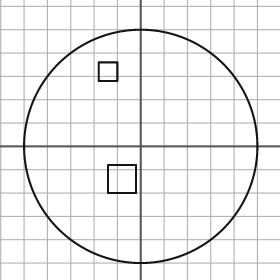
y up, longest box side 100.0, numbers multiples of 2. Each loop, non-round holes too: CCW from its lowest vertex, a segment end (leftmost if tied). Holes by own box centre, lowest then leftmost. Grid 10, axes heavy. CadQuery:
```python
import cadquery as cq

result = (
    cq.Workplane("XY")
    .moveTo(0.0, 0.0)
    .circle(50.0)
    .moveTo(-14.0, -20.0)
    .lineTo(-2.0, -20.0)
    .lineTo(-2.0, -8.0)
    .lineTo(-14.0, -8.0)
    .close()
    .moveTo(-18.0, 28.0)
    .lineTo(-10.0, 28.0)
    .lineTo(-10.0, 36.0)
    .lineTo(-18.0, 36.0)
    .close()
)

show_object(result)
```